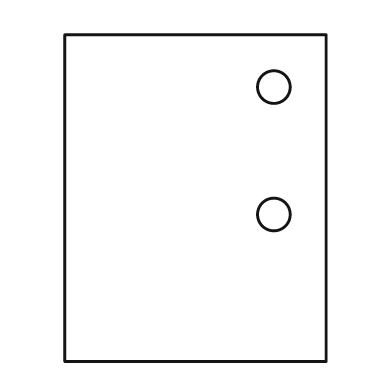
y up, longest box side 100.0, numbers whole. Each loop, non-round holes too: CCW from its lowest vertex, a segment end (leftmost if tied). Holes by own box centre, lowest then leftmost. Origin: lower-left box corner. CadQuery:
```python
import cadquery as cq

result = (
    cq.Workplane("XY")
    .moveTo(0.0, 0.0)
    .lineTo(80.0, 0.0)
    .lineTo(80.0, 100.0)
    .lineTo(0.0, 100.0)
    .close()
    .moveTo(64.0, 45.0)
    .circle(5.0)
    .moveTo(64.0, 84.0)
    .circle(5.0)
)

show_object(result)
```